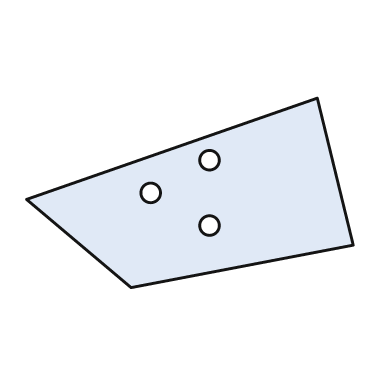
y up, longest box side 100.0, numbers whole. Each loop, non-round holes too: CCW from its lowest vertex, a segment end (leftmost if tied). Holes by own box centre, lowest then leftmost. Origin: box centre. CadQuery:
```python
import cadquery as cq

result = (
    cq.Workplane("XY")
    .moveTo(-18.0, -29.0)
    .lineTo(50.0, -16.0)
    .lineTo(39.0, 29.0)
    .lineTo(-50.0, -2.0)
    .close()
    .moveTo(6.0, -10.0)
    .circle(3.0)
    .moveTo(-12.0, 0.0)
    .circle(3.0)
    .moveTo(6.0, 10.0)
    .circle(3.0)
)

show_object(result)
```